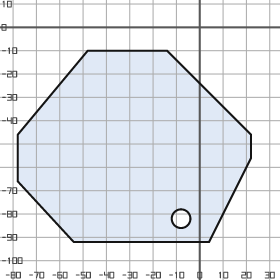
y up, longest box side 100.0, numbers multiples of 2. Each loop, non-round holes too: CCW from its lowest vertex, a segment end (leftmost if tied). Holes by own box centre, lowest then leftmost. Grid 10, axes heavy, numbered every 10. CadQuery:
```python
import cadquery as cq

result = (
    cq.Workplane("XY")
    .moveTo(-54.0, -92.0)
    .lineTo(4.0, -92.0)
    .lineTo(22.0, -56.0)
    .lineTo(22.0, -46.0)
    .lineTo(-14.0, -10.0)
    .lineTo(-48.0, -10.0)
    .lineTo(-78.0, -46.0)
    .lineTo(-78.0, -66.0)
    .close()
    .moveTo(-8.0, -82.0)
    .circle(4.0)
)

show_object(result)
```